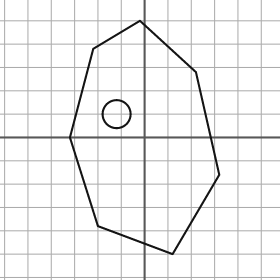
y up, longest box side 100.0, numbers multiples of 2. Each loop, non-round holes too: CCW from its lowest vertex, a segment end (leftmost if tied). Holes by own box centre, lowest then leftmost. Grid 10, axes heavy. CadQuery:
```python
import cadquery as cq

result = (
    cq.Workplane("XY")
    .moveTo(12.0, -50.0)
    .lineTo(32.0, -16.0)
    .lineTo(22.0, 28.0)
    .lineTo(-2.0, 50.0)
    .lineTo(-22.0, 38.0)
    .lineTo(-32.0, 0.0)
    .lineTo(-20.0, -38.0)
    .close()
    .moveTo(-12.0, 10.0)
    .circle(6.0)
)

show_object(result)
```